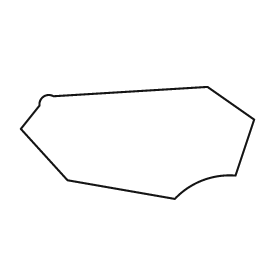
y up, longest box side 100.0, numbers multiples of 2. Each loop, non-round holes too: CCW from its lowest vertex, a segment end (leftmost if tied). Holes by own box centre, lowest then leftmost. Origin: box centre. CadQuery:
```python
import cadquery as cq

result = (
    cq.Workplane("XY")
    .moveTo(16.0, -24.0)
    .threePointArc((28.0, -16.0), (42.0, -14.0))
    .lineTo(50.0, 10.0)
    .lineTo(30.0, 24.0)
    .lineTo(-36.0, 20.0)
    .threePointArc((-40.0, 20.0), (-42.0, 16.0))
    .lineTo(-50.0, 6.0)
    .lineTo(-30.0, -16.0)
    .close()
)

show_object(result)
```